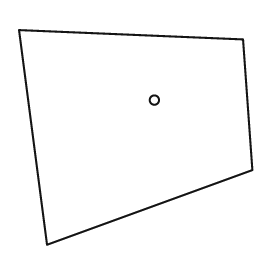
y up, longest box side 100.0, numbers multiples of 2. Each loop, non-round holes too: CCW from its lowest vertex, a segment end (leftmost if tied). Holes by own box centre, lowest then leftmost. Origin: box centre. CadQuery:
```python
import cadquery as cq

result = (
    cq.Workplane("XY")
    .moveTo(-38.0, -46.0)
    .lineTo(50.0, -14.0)
    .lineTo(46.0, 42.0)
    .lineTo(-50.0, 46.0)
    .close()
    .moveTo(8.0, 16.0)
    .circle(2.0)
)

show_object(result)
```